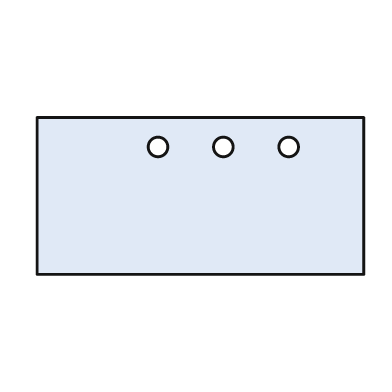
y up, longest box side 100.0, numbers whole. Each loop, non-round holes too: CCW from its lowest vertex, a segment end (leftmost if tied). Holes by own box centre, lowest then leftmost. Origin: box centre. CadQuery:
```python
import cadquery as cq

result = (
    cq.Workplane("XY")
    .moveTo(-50.0, -24.0)
    .lineTo(50.0, -24.0)
    .lineTo(50.0, 24.0)
    .lineTo(-50.0, 24.0)
    .close()
    .moveTo(-13.0, 15.0)
    .circle(3.0)
    .moveTo(7.0, 15.0)
    .circle(3.0)
    .moveTo(27.0, 15.0)
    .circle(3.0)
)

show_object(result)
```